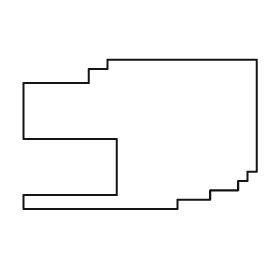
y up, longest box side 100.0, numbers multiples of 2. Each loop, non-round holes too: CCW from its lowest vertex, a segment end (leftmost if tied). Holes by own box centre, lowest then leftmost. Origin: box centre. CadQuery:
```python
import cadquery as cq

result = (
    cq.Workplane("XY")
    .moveTo(-50.0, -32.0)
    .lineTo(16.0, -32.0)
    .lineTo(16.0, -28.0)
    .lineTo(30.0, -28.0)
    .lineTo(30.0, -24.0)
    .lineTo(42.0, -24.0)
    .lineTo(42.0, -20.0)
    .lineTo(46.0, -20.0)
    .lineTo(46.0, -16.0)
    .lineTo(50.0, -16.0)
    .lineTo(50.0, 32.0)
    .lineTo(-14.0, 32.0)
    .lineTo(-14.0, 28.0)
    .lineTo(-22.0, 28.0)
    .lineTo(-22.0, 22.0)
    .lineTo(-50.0, 22.0)
    .lineTo(-50.0, -2.0)
    .lineTo(-10.0, -2.0)
    .lineTo(-10.0, -26.0)
    .lineTo(-50.0, -26.0)
    .close()
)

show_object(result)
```